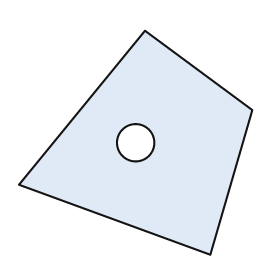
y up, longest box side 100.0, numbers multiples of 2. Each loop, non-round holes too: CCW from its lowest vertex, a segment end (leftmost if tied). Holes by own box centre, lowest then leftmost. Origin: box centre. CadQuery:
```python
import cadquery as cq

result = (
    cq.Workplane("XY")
    .moveTo(32.0, -48.0)
    .lineTo(50.0, 14.0)
    .lineTo(4.0, 48.0)
    .lineTo(-50.0, -18.0)
    .close()
    .moveTo(0.0, 0.0)
    .circle(8.0)
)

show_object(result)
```